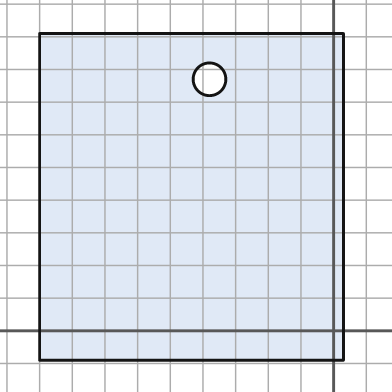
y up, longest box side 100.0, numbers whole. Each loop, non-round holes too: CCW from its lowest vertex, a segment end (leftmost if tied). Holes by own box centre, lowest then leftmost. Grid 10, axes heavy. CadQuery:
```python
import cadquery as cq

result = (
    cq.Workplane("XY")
    .moveTo(-90.0, -9.0)
    .lineTo(3.0, -9.0)
    .lineTo(3.0, 91.0)
    .lineTo(-90.0, 91.0)
    .close()
    .moveTo(-38.0, 77.0)
    .circle(5.0)
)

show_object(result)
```